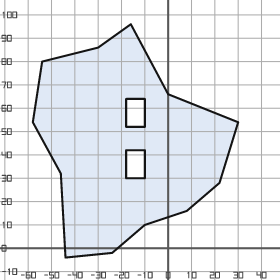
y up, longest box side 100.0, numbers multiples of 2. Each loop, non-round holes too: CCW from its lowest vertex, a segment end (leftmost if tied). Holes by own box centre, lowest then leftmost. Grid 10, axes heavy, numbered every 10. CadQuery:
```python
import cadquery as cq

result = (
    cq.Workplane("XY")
    .moveTo(-44.0, -4.0)
    .lineTo(-24.0, -2.0)
    .lineTo(-10.0, 10.0)
    .lineTo(8.0, 16.0)
    .lineTo(22.0, 28.0)
    .lineTo(30.0, 54.0)
    .lineTo(0.0, 66.0)
    .lineTo(-16.0, 96.0)
    .lineTo(-30.0, 86.0)
    .lineTo(-54.0, 80.0)
    .lineTo(-58.0, 54.0)
    .lineTo(-46.0, 32.0)
    .close()
    .moveTo(-18.0, 30.0)
    .lineTo(-10.0, 30.0)
    .lineTo(-10.0, 42.0)
    .lineTo(-18.0, 42.0)
    .close()
    .moveTo(-18.0, 52.0)
    .lineTo(-10.0, 52.0)
    .lineTo(-10.0, 64.0)
    .lineTo(-18.0, 64.0)
    .close()
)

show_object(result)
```